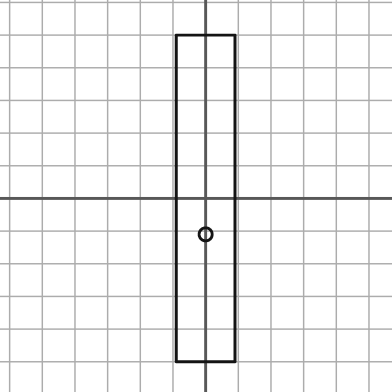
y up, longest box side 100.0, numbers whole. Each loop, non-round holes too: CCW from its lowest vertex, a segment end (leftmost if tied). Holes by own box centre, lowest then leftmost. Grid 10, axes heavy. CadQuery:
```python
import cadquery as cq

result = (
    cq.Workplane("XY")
    .moveTo(-9.0, -50.0)
    .lineTo(9.0, -50.0)
    .lineTo(9.0, 50.0)
    .lineTo(-9.0, 50.0)
    .close()
    .moveTo(0.0, -11.0)
    .circle(2.0)
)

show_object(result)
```